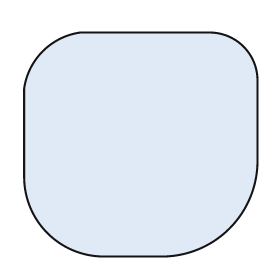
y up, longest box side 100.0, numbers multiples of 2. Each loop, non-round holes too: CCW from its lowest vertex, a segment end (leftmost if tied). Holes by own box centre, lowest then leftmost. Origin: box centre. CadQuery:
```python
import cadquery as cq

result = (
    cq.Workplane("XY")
    .moveTo(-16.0, -48.0)
    .lineTo(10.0, -48.0)
    .threePointArc((38.0, -36.0), (50.0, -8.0))
    .lineTo(50.0, 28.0)
    .threePointArc((44.0, 42.0), (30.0, 48.0))
    .lineTo(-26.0, 48.0)
    .threePointArc((-42.0, 40.0), (-50.0, 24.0))
    .lineTo(-50.0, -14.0)
    .threePointArc((-40.0, -38.0), (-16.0, -48.0))
    .close()
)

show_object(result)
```